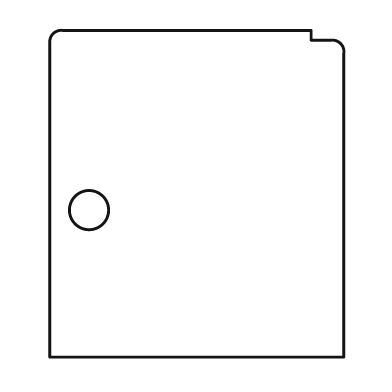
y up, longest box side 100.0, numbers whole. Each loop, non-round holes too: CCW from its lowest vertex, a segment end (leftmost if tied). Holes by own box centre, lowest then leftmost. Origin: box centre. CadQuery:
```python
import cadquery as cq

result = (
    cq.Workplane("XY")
    .moveTo(-45.0, -50.0)
    .lineTo(45.0, -50.0)
    .lineTo(45.0, 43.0)
    .threePointArc((44.0, 46.0), (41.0, 47.0))
    .lineTo(35.0, 47.0)
    .lineTo(35.0, 50.0)
    .lineTo(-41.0, 50.0)
    .threePointArc((-44.0, 49.0), (-45.0, 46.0))
    .close()
    .moveTo(-33.0, -5.0)
    .circle(6.0)
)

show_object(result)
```